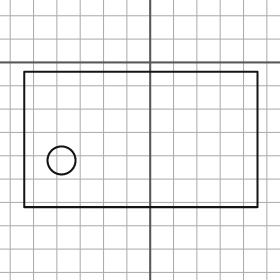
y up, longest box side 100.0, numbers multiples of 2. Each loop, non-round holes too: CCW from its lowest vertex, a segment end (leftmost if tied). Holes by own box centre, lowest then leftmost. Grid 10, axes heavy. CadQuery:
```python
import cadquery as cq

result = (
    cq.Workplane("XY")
    .moveTo(-54.0, -62.0)
    .lineTo(46.0, -62.0)
    .lineTo(46.0, -4.0)
    .lineTo(-54.0, -4.0)
    .close()
    .moveTo(-38.0, -42.0)
    .circle(6.0)
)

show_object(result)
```